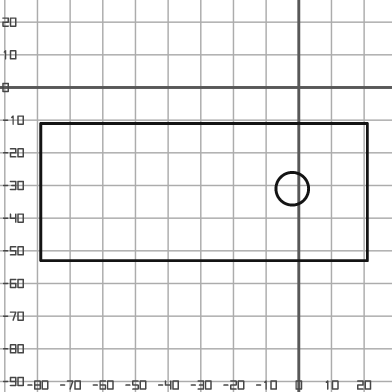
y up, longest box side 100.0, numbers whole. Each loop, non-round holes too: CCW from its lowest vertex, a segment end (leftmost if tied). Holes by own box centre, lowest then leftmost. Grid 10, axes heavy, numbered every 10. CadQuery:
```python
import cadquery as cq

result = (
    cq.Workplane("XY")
    .moveTo(-79.0, -53.0)
    .lineTo(21.0, -53.0)
    .lineTo(21.0, -11.0)
    .lineTo(-79.0, -11.0)
    .close()
    .moveTo(-2.0, -31.0)
    .circle(5.0)
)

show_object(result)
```